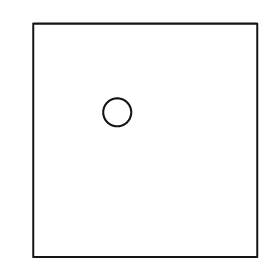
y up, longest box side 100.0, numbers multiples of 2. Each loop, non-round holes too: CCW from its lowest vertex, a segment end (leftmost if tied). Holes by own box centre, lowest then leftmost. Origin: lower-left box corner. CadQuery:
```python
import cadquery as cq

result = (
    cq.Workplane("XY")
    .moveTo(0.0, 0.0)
    .lineTo(96.0, 0.0)
    .lineTo(96.0, 100.0)
    .lineTo(0.0, 100.0)
    .close()
    .moveTo(36.0, 62.0)
    .circle(6.0)
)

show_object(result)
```